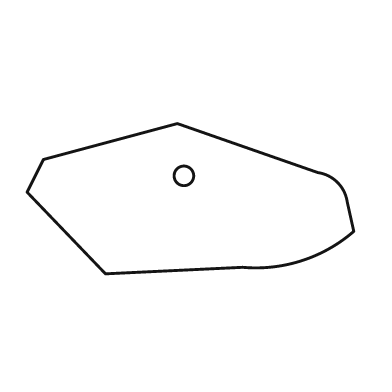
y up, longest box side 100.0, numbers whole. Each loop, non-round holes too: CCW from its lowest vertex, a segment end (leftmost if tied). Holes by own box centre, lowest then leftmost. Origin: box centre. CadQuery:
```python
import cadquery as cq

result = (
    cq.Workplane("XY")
    .moveTo(-26.0, -23.0)
    .lineTo(16.0, -21.0)
    .threePointArc((34.0, -19.0), (50.0, -10.0))
    .lineTo(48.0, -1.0)
    .threePointArc((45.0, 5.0), (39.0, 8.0))
    .lineTo(-4.0, 23.0)
    .lineTo(-45.0, 12.0)
    .lineTo(-50.0, 2.0)
    .close()
    .moveTo(-2.0, 7.0)
    .circle(3.0)
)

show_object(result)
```